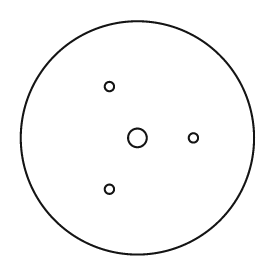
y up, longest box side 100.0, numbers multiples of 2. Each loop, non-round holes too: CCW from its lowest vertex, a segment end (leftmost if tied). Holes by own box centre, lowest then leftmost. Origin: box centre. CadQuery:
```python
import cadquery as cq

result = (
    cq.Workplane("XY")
    .moveTo(0.0, 0.0)
    .circle(50.0)
    .moveTo(-12.0, -22.0)
    .circle(2.0)
    .moveTo(0.0, 0.0)
    .circle(4.0)
    .moveTo(24.0, 0.0)
    .circle(2.0)
    .moveTo(-12.0, 22.0)
    .circle(2.0)
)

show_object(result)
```